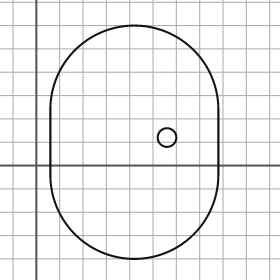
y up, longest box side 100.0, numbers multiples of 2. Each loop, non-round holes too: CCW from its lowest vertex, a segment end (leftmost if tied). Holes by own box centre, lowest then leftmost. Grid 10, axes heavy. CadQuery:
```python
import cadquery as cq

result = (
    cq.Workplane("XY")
    .moveTo(6.0, -4.0)
    .threePointArc((42.0, -40.0), (78.0, -4.0))
    .lineTo(78.0, 24.0)
    .threePointArc((42.0, 60.0), (6.0, 24.0))
    .close()
    .moveTo(56.0, 12.0)
    .circle(4.0)
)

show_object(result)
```